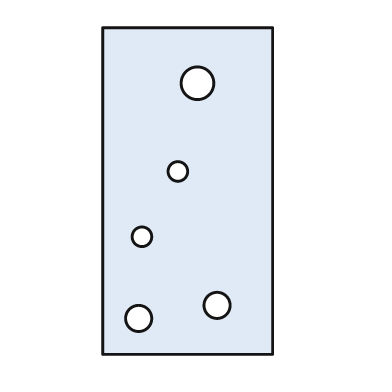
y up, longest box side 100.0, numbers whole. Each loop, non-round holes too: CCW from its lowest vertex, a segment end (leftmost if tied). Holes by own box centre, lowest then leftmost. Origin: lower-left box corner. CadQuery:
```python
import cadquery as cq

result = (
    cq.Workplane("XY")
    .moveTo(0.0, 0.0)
    .lineTo(52.0, 0.0)
    .lineTo(52.0, 100.0)
    .lineTo(0.0, 100.0)
    .close()
    .moveTo(11.0, 11.0)
    .circle(4.0)
    .moveTo(35.0, 15.0)
    .circle(4.0)
    .moveTo(12.0, 36.0)
    .circle(3.0)
    .moveTo(23.0, 56.0)
    .circle(3.0)
    .moveTo(29.0, 83.0)
    .circle(5.0)
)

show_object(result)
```